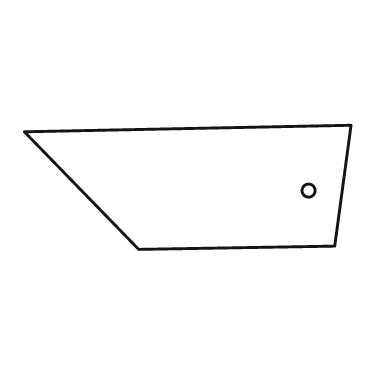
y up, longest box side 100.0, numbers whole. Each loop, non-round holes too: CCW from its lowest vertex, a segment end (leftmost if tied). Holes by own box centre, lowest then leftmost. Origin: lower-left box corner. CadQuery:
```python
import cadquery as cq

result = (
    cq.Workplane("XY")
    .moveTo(35.0, 0.0)
    .lineTo(95.0, 1.0)
    .lineTo(100.0, 38.0)
    .lineTo(0.0, 36.0)
    .close()
    .moveTo(87.0, 18.0)
    .circle(2.0)
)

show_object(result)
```